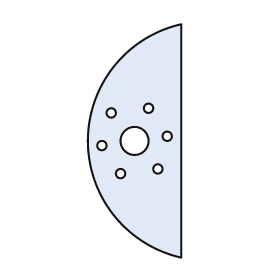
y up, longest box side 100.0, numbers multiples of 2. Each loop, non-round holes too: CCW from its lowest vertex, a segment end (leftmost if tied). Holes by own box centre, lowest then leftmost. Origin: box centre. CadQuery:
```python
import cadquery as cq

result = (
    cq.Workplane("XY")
    .moveTo(20.0, -50.0)
    .lineTo(20.0, 50.0)
    .threePointArc((-20.0, 0.0), (20.0, -50.0))
    .close()
    .moveTo(-6.0, -14.0)
    .circle(2.0)
    .moveTo(10.0, -12.0)
    .circle(2.0)
    .moveTo(-14.0, -2.0)
    .circle(2.0)
    .moveTo(0.0, 0.0)
    .circle(6.0)
    .moveTo(14.0, 2.0)
    .circle(2.0)
    .moveTo(-10.0, 12.0)
    .circle(2.0)
    .moveTo(6.0, 14.0)
    .circle(2.0)
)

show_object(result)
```